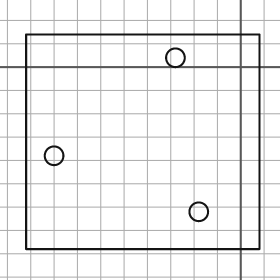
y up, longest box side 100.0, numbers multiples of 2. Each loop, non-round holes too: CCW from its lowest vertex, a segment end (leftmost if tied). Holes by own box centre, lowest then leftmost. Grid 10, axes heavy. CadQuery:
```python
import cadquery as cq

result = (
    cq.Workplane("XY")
    .moveTo(-92.0, -78.0)
    .lineTo(8.0, -78.0)
    .lineTo(8.0, 14.0)
    .lineTo(-92.0, 14.0)
    .close()
    .moveTo(-18.0, -62.0)
    .circle(4.0)
    .moveTo(-80.0, -38.0)
    .circle(4.0)
    .moveTo(-28.0, 4.0)
    .circle(4.0)
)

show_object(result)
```